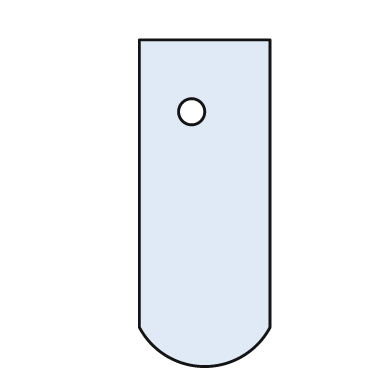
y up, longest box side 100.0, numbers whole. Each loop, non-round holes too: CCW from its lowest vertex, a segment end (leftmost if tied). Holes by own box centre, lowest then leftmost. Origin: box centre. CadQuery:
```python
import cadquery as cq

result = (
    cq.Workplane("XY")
    .moveTo(-20.0, -38.0)
    .threePointArc((0.0, -50.0), (20.0, -38.0))
    .lineTo(20.0, 50.0)
    .lineTo(-20.0, 50.0)
    .close()
    .moveTo(-4.0, 28.0)
    .circle(4.0)
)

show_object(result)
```